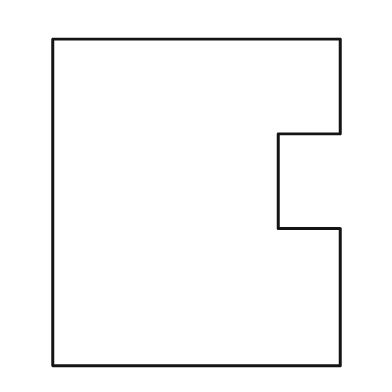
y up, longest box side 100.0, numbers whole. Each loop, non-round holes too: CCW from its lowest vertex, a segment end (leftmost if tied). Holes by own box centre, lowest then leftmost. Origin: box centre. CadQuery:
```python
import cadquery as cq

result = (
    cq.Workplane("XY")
    .moveTo(-44.0, -50.0)
    .lineTo(44.0, -50.0)
    .lineTo(44.0, -8.0)
    .lineTo(25.0, -8.0)
    .lineTo(25.0, 21.0)
    .lineTo(44.0, 21.0)
    .lineTo(44.0, 50.0)
    .lineTo(-44.0, 50.0)
    .close()
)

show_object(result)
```